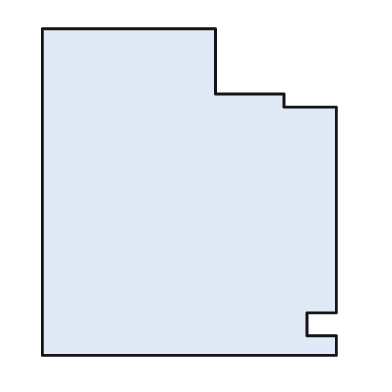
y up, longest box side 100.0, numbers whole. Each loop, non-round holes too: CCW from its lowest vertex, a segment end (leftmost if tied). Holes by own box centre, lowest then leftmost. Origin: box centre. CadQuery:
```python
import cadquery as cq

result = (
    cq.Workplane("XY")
    .moveTo(-45.0, -50.0)
    .lineTo(45.0, -50.0)
    .lineTo(45.0, -44.0)
    .lineTo(36.0, -44.0)
    .lineTo(36.0, -37.0)
    .lineTo(45.0, -37.0)
    .lineTo(45.0, 26.0)
    .lineTo(29.0, 26.0)
    .lineTo(29.0, 30.0)
    .lineTo(8.0, 30.0)
    .lineTo(8.0, 50.0)
    .lineTo(-45.0, 50.0)
    .close()
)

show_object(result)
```